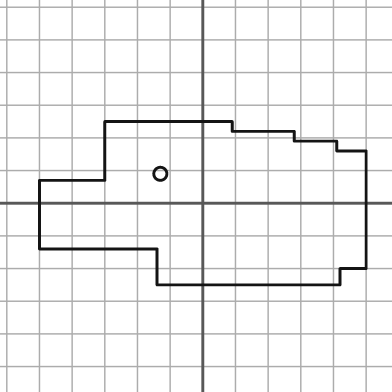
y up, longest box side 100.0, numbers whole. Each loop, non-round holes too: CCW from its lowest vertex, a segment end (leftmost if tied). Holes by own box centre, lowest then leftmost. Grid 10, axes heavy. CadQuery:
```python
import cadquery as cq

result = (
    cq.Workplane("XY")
    .moveTo(-14.0, -25.0)
    .lineTo(42.0, -25.0)
    .lineTo(42.0, -20.0)
    .lineTo(50.0, -20.0)
    .lineTo(50.0, 16.0)
    .lineTo(41.0, 16.0)
    .lineTo(41.0, 19.0)
    .lineTo(28.0, 19.0)
    .lineTo(28.0, 22.0)
    .lineTo(9.0, 22.0)
    .lineTo(9.0, 25.0)
    .lineTo(-30.0, 25.0)
    .lineTo(-30.0, 7.0)
    .lineTo(-50.0, 7.0)
    .lineTo(-50.0, -14.0)
    .lineTo(-14.0, -14.0)
    .close()
    .moveTo(-13.0, 9.0)
    .circle(2.0)
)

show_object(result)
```